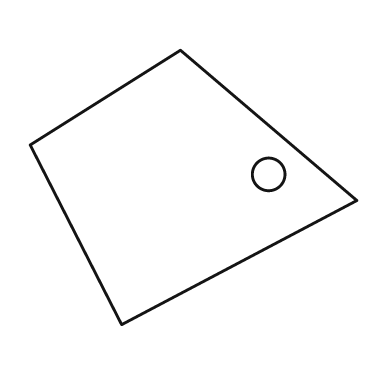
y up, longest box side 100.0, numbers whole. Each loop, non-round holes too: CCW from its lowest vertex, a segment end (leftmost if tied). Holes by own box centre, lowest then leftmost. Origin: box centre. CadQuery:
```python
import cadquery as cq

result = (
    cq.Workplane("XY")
    .moveTo(-22.0, -42.0)
    .lineTo(50.0, -4.0)
    .lineTo(-4.0, 42.0)
    .lineTo(-50.0, 13.0)
    .close()
    .moveTo(23.0, 4.0)
    .circle(5.0)
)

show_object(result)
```